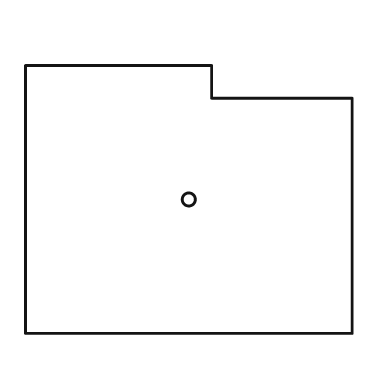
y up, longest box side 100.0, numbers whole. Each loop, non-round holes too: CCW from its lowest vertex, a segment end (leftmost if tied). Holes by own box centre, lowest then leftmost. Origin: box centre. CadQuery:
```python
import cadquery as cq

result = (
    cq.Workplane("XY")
    .moveTo(-50.0, -41.0)
    .lineTo(50.0, -41.0)
    .lineTo(50.0, 31.0)
    .lineTo(7.0, 31.0)
    .lineTo(7.0, 41.0)
    .lineTo(-50.0, 41.0)
    .close()
    .moveTo(0.0, 0.0)
    .circle(2.0)
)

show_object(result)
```